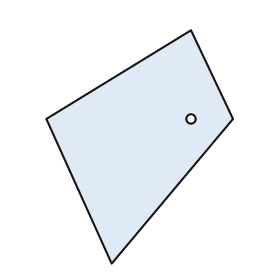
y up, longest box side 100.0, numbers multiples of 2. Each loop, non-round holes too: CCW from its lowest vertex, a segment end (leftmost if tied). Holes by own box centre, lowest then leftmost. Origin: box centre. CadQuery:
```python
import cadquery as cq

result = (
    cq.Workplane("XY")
    .moveTo(-12.0, -50.0)
    .lineTo(40.0, 12.0)
    .lineTo(22.0, 50.0)
    .lineTo(-40.0, 12.0)
    .close()
    .moveTo(22.0, 12.0)
    .circle(2.0)
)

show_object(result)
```